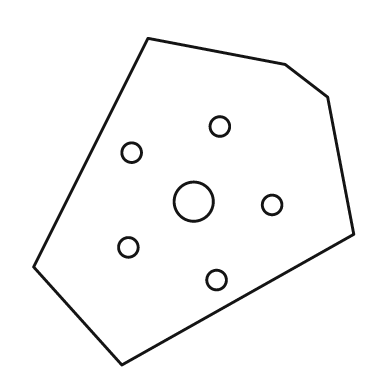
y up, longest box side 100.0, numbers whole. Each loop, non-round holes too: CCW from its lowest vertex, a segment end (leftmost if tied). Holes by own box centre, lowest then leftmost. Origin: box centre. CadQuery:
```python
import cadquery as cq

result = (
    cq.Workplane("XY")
    .moveTo(-22.0, -50.0)
    .lineTo(49.0, -10.0)
    .lineTo(41.0, 32.0)
    .lineTo(28.0, 42.0)
    .lineTo(-14.0, 50.0)
    .lineTo(-49.0, -20.0)
    .close()
    .moveTo(7.0, -24.0)
    .circle(3.0)
    .moveTo(-20.0, -14.0)
    .circle(3.0)
    .moveTo(24.0, -1.0)
    .circle(3.0)
    .moveTo(0.0, 0.0)
    .circle(6.0)
    .moveTo(-19.0, 15.0)
    .circle(3.0)
    .moveTo(8.0, 23.0)
    .circle(3.0)
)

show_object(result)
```